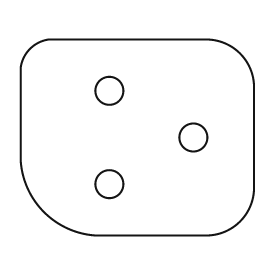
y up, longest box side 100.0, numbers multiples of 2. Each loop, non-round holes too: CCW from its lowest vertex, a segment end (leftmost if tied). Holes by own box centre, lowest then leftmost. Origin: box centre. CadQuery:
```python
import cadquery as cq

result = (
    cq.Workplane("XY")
    .moveTo(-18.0, -42.0)
    .lineTo(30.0, -42.0)
    .threePointArc((44.0, -36.0), (50.0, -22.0))
    .lineTo(50.0, 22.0)
    .threePointArc((44.0, 36.0), (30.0, 42.0))
    .lineTo(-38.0, 42.0)
    .threePointArc((-46.0, 38.0), (-50.0, 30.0))
    .lineTo(-50.0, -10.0)
    .threePointArc((-40.0, -32.0), (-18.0, -42.0))
    .close()
    .moveTo(-12.0, -20.0)
    .circle(6.0)
    .moveTo(24.0, 0.0)
    .circle(6.0)
    .moveTo(-12.0, 20.0)
    .circle(6.0)
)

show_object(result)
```